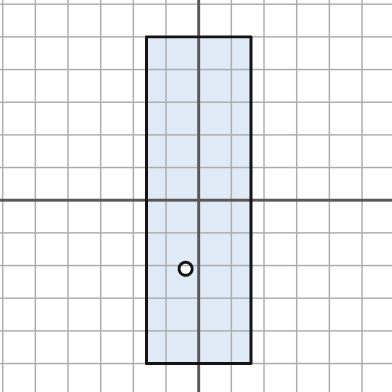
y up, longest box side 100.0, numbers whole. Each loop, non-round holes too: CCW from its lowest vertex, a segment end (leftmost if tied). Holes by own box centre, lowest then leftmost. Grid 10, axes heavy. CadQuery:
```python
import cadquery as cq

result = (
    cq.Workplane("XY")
    .moveTo(-16.0, -50.0)
    .lineTo(16.0, -50.0)
    .lineTo(16.0, 50.0)
    .lineTo(-16.0, 50.0)
    .close()
    .moveTo(-4.0, -21.0)
    .circle(2.0)
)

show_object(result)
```